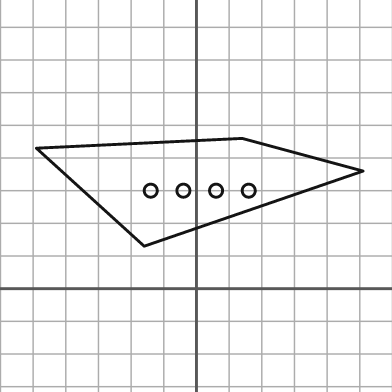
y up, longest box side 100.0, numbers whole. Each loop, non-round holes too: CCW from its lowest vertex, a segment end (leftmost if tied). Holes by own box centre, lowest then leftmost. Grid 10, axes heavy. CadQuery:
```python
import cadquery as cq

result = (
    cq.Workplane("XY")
    .moveTo(-16.0, 13.0)
    .lineTo(51.0, 36.0)
    .lineTo(14.0, 46.0)
    .lineTo(-49.0, 43.0)
    .close()
    .moveTo(-14.0, 30.0)
    .circle(2.0)
    .moveTo(-4.0, 30.0)
    .circle(2.0)
    .moveTo(6.0, 30.0)
    .circle(2.0)
    .moveTo(16.0, 30.0)
    .circle(2.0)
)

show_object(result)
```